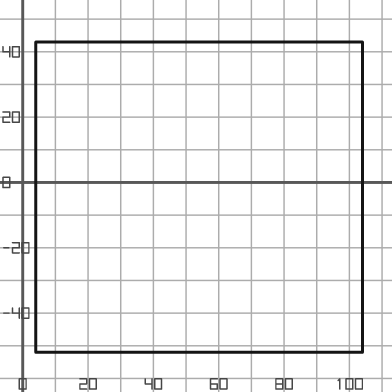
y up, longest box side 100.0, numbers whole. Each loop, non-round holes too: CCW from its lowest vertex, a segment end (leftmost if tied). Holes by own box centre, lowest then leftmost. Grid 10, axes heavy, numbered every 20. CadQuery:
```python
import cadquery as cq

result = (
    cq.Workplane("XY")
    .moveTo(4.0, -52.0)
    .lineTo(104.0, -52.0)
    .lineTo(104.0, 43.0)
    .lineTo(4.0, 43.0)
    .close()
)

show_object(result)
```